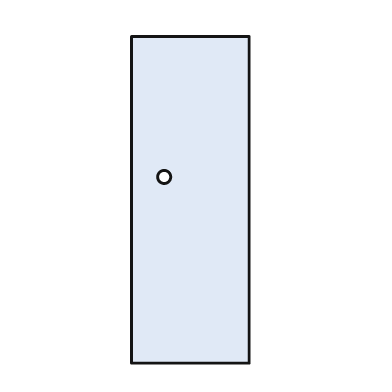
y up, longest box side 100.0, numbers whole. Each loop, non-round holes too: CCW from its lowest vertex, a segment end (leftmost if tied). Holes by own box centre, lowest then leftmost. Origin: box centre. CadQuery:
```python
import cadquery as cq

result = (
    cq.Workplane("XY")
    .moveTo(-18.0, -50.0)
    .lineTo(18.0, -50.0)
    .lineTo(18.0, 50.0)
    .lineTo(-18.0, 50.0)
    .close()
    .moveTo(-8.0, 7.0)
    .circle(2.0)
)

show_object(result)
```